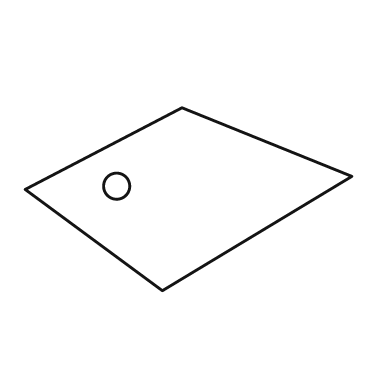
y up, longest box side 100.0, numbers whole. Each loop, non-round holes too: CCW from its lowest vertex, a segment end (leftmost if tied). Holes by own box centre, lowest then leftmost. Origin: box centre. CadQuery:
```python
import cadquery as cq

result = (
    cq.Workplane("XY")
    .moveTo(-8.0, -28.0)
    .lineTo(50.0, 7.0)
    .lineTo(-2.0, 28.0)
    .lineTo(-50.0, 3.0)
    .close()
    .moveTo(-22.0, 4.0)
    .circle(4.0)
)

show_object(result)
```